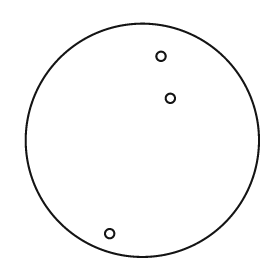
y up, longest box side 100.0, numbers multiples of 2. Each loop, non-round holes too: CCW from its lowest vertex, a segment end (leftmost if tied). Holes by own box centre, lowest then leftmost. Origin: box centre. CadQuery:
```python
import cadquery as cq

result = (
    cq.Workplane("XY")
    .moveTo(0.0, 0.0)
    .circle(50.0)
    .moveTo(-14.0, -40.0)
    .circle(2.0)
    .moveTo(12.0, 18.0)
    .circle(2.0)
    .moveTo(8.0, 36.0)
    .circle(2.0)
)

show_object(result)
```